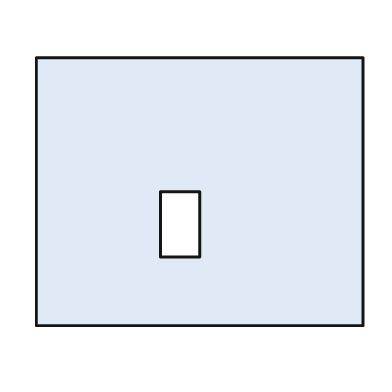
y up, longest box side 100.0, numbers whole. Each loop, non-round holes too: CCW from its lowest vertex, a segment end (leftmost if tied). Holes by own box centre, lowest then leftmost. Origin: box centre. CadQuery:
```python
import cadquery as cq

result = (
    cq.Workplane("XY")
    .moveTo(-50.0, -41.0)
    .lineTo(50.0, -41.0)
    .lineTo(50.0, 41.0)
    .lineTo(-50.0, 41.0)
    .close()
    .moveTo(-12.0, -20.0)
    .lineTo(0.0, -20.0)
    .lineTo(0.0, 0.0)
    .lineTo(-12.0, 0.0)
    .close()
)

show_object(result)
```